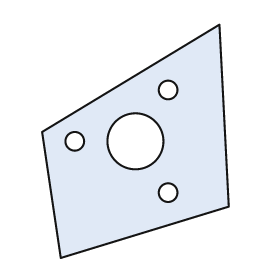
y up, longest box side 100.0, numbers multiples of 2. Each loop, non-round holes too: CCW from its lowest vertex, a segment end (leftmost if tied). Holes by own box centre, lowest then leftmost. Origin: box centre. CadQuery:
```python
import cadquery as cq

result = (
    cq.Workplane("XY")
    .moveTo(-32.0, -50.0)
    .lineTo(40.0, -28.0)
    .lineTo(36.0, 50.0)
    .lineTo(-40.0, 4.0)
    .close()
    .moveTo(14.0, -22.0)
    .circle(4.0)
    .moveTo(-26.0, 0.0)
    .circle(4.0)
    .moveTo(0.0, 0.0)
    .circle(12.0)
    .moveTo(14.0, 22.0)
    .circle(4.0)
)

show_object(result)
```